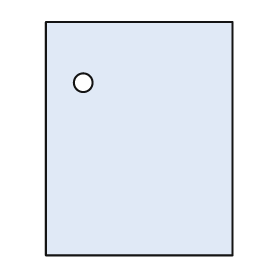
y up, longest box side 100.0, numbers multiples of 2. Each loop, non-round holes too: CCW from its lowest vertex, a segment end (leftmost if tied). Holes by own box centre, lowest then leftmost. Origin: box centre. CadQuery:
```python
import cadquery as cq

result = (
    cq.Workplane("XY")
    .moveTo(-40.0, -50.0)
    .lineTo(40.0, -50.0)
    .lineTo(40.0, 50.0)
    .lineTo(-40.0, 50.0)
    .close()
    .moveTo(-24.0, 24.0)
    .circle(4.0)
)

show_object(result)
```